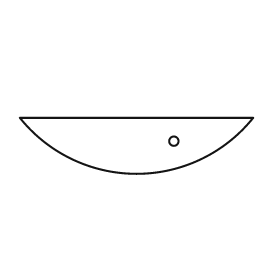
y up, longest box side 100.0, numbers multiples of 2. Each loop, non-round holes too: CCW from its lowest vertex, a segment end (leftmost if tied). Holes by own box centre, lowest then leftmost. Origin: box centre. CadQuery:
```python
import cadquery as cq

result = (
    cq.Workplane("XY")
    .moveTo(-50.0, 12.0)
    .threePointArc((0.0, -12.0), (50.0, 12.0))
    .close()
    .moveTo(16.0, 2.0)
    .circle(2.0)
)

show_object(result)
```